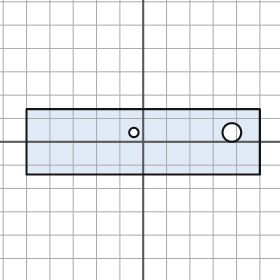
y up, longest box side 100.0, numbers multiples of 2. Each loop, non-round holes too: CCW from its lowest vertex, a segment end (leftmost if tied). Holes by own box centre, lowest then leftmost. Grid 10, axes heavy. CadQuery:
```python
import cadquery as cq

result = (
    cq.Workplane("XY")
    .moveTo(-50.0, -14.0)
    .lineTo(50.0, -14.0)
    .lineTo(50.0, 14.0)
    .lineTo(-50.0, 14.0)
    .close()
    .moveTo(-4.0, 4.0)
    .circle(2.0)
    .moveTo(38.0, 4.0)
    .circle(4.0)
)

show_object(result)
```